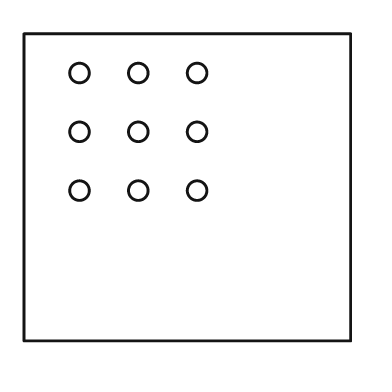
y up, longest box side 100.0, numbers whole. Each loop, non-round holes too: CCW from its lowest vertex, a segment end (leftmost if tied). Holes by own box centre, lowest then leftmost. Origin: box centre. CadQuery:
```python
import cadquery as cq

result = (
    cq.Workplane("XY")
    .moveTo(-50.0, -47.0)
    .lineTo(50.0, -47.0)
    .lineTo(50.0, 47.0)
    .lineTo(-50.0, 47.0)
    .close()
    .moveTo(-33.0, -1.0)
    .circle(3.0)
    .moveTo(-15.0, -1.0)
    .circle(3.0)
    .moveTo(3.0, -1.0)
    .circle(3.0)
    .moveTo(-33.0, 17.0)
    .circle(3.0)
    .moveTo(-15.0, 17.0)
    .circle(3.0)
    .moveTo(3.0, 17.0)
    .circle(3.0)
    .moveTo(-33.0, 35.0)
    .circle(3.0)
    .moveTo(-15.0, 35.0)
    .circle(3.0)
    .moveTo(3.0, 35.0)
    .circle(3.0)
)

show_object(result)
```